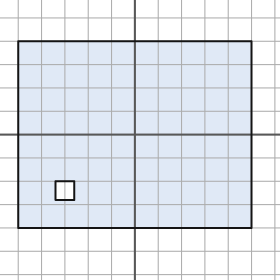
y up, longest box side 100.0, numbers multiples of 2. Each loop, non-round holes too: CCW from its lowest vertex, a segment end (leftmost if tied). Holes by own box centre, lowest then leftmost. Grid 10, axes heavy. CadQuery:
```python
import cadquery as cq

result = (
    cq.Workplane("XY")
    .moveTo(-50.0, -40.0)
    .lineTo(50.0, -40.0)
    .lineTo(50.0, 40.0)
    .lineTo(-50.0, 40.0)
    .close()
    .moveTo(-34.0, -28.0)
    .lineTo(-26.0, -28.0)
    .lineTo(-26.0, -20.0)
    .lineTo(-34.0, -20.0)
    .close()
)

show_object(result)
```